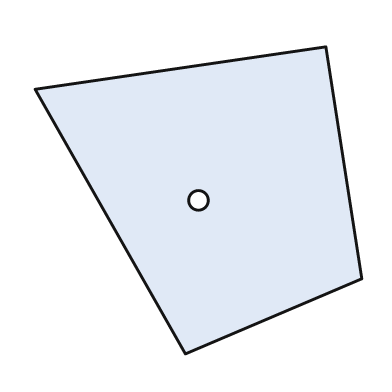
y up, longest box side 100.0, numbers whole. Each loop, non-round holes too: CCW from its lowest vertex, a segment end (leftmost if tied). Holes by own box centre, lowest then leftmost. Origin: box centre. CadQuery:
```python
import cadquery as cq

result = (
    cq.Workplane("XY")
    .moveTo(-4.0, -47.0)
    .lineTo(50.0, -24.0)
    .lineTo(39.0, 47.0)
    .lineTo(-50.0, 34.0)
    .close()
    .moveTo(0.0, 0.0)
    .circle(3.0)
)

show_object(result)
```